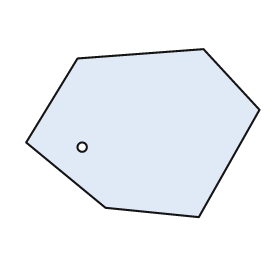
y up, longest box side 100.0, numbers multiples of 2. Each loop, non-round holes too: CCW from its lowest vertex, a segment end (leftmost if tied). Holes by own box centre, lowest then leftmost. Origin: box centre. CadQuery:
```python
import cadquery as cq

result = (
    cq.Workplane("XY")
    .moveTo(24.0, -36.0)
    .lineTo(50.0, 10.0)
    .lineTo(26.0, 36.0)
    .lineTo(-28.0, 32.0)
    .lineTo(-50.0, -4.0)
    .lineTo(-16.0, -32.0)
    .close()
    .moveTo(-26.0, -6.0)
    .circle(2.0)
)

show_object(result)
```